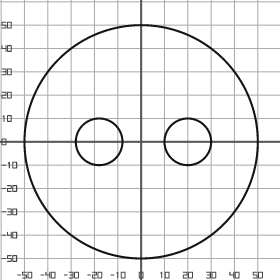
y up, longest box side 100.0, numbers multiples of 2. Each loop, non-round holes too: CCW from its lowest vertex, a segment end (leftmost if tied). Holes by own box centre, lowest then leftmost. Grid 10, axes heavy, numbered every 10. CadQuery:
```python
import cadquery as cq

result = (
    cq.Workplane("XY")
    .moveTo(0.0, 0.0)
    .circle(50.0)
    .moveTo(-18.0, 0.0)
    .circle(10.0)
    .moveTo(20.0, 0.0)
    .circle(10.0)
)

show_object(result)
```